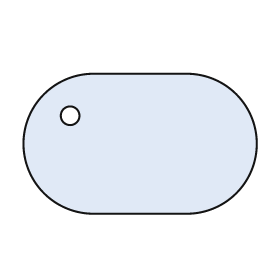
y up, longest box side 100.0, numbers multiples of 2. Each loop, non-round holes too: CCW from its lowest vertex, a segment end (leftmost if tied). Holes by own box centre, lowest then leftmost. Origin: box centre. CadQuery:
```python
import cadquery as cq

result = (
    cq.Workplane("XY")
    .moveTo(-20.0, -30.0)
    .lineTo(20.0, -30.0)
    .threePointArc((50.0, 0.0), (20.0, 30.0))
    .lineTo(-20.0, 30.0)
    .threePointArc((-50.0, 0.0), (-20.0, -30.0))
    .close()
    .moveTo(-30.0, 12.0)
    .circle(4.0)
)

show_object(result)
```